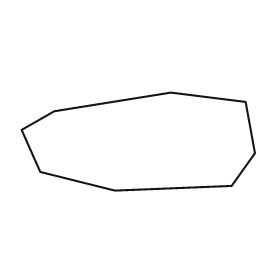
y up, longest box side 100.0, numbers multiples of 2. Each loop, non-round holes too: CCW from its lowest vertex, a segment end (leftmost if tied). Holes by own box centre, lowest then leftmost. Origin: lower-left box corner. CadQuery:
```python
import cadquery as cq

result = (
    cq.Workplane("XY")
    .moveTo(40.0, 0.0)
    .lineTo(90.0, 2.0)
    .lineTo(100.0, 16.0)
    .lineTo(96.0, 38.0)
    .lineTo(64.0, 42.0)
    .lineTo(14.0, 34.0)
    .lineTo(0.0, 26.0)
    .lineTo(8.0, 8.0)
    .close()
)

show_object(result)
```